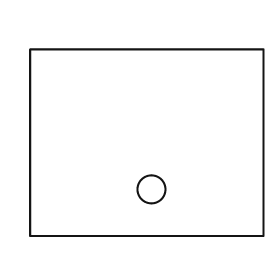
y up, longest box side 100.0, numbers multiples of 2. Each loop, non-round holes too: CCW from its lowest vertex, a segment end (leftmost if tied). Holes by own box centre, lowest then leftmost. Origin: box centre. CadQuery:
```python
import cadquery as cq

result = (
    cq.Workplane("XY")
    .moveTo(-50.0, -40.0)
    .lineTo(50.0, -40.0)
    .lineTo(50.0, 40.0)
    .lineTo(-50.0, 40.0)
    .close()
    .moveTo(2.0, -20.0)
    .circle(6.0)
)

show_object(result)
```